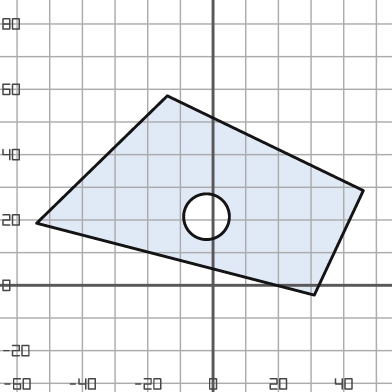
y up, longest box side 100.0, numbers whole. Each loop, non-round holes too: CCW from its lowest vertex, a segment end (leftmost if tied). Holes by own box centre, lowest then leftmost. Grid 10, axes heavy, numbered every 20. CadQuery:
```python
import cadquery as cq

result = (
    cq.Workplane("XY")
    .moveTo(31.0, -3.0)
    .lineTo(46.0, 29.0)
    .lineTo(-14.0, 58.0)
    .lineTo(-54.0, 19.0)
    .close()
    .moveTo(-2.0, 21.0)
    .circle(7.0)
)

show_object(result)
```